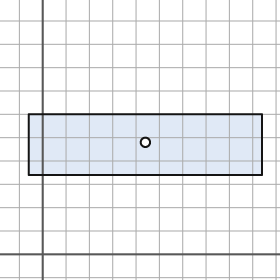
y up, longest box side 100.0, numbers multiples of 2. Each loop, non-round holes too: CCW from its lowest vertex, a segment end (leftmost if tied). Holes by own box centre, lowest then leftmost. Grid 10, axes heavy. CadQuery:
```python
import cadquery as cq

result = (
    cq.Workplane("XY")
    .moveTo(-6.0, 34.0)
    .lineTo(94.0, 34.0)
    .lineTo(94.0, 60.0)
    .lineTo(-6.0, 60.0)
    .close()
    .moveTo(44.0, 48.0)
    .circle(2.0)
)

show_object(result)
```